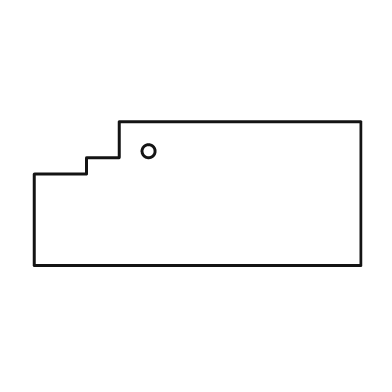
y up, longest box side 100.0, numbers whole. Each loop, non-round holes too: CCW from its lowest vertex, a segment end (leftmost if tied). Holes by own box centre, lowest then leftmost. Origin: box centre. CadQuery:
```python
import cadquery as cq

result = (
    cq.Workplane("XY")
    .moveTo(-50.0, -22.0)
    .lineTo(50.0, -22.0)
    .lineTo(50.0, 22.0)
    .lineTo(-24.0, 22.0)
    .lineTo(-24.0, 11.0)
    .lineTo(-34.0, 11.0)
    .lineTo(-34.0, 6.0)
    .lineTo(-50.0, 6.0)
    .close()
    .moveTo(-15.0, 13.0)
    .circle(2.0)
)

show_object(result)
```